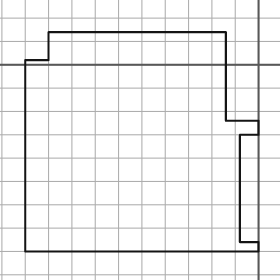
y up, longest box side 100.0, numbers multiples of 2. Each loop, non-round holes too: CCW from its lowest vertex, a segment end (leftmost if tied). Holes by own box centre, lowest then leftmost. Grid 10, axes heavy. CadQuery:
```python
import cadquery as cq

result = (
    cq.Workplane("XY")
    .moveTo(-100.0, -80.0)
    .lineTo(0.0, -80.0)
    .lineTo(0.0, -76.0)
    .lineTo(-8.0, -76.0)
    .lineTo(-8.0, -30.0)
    .lineTo(0.0, -30.0)
    .lineTo(0.0, -24.0)
    .lineTo(-14.0, -24.0)
    .lineTo(-14.0, 14.0)
    .lineTo(-90.0, 14.0)
    .lineTo(-90.0, 2.0)
    .lineTo(-100.0, 2.0)
    .close()
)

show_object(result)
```